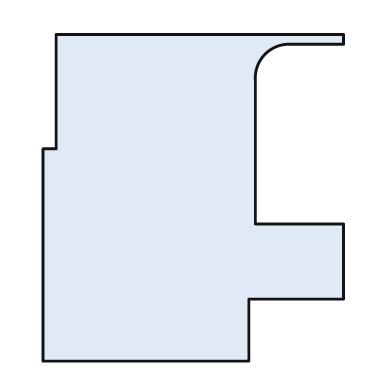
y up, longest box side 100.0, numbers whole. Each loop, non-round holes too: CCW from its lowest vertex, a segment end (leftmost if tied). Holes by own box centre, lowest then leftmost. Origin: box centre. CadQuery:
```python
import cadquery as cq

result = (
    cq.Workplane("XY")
    .moveTo(-46.0, -50.0)
    .lineTo(17.0, -50.0)
    .lineTo(17.0, -31.0)
    .lineTo(46.0, -31.0)
    .lineTo(46.0, -8.0)
    .lineTo(19.0, -8.0)
    .lineTo(19.0, 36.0)
    .threePointArc((22.0, 44.0), (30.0, 47.0))
    .lineTo(46.0, 47.0)
    .lineTo(46.0, 50.0)
    .lineTo(-42.0, 50.0)
    .lineTo(-42.0, 15.0)
    .lineTo(-46.0, 15.0)
    .close()
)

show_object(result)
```